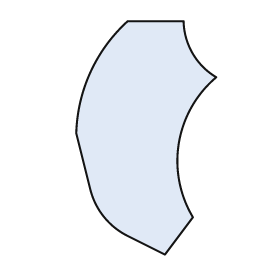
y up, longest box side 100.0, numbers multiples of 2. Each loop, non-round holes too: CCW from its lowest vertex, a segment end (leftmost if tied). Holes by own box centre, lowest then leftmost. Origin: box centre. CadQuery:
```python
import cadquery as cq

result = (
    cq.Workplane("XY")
    .moveTo(8.0, -50.0)
    .lineTo(20.0, -34.0)
    .threePointArc((14.0, -2.0), (30.0, 26.0))
    .threePointArc((20.0, 36.0), (16.0, 50.0))
    .lineTo(-8.0, 50.0)
    .threePointArc((-24.0, 28.0), (-30.0, 2.0))
    .lineTo(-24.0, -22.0)
    .threePointArc((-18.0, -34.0), (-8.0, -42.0))
    .close()
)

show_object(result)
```